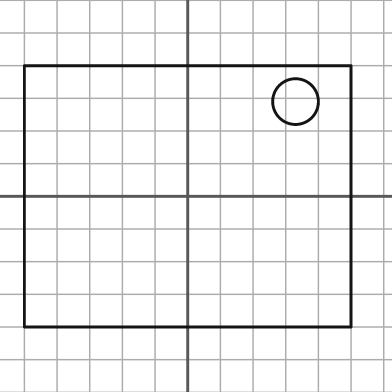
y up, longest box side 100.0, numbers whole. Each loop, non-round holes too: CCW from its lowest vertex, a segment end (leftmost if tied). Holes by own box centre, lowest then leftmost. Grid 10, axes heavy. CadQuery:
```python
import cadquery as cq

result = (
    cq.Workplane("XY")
    .moveTo(-50.0, -40.0)
    .lineTo(50.0, -40.0)
    .lineTo(50.0, 40.0)
    .lineTo(-50.0, 40.0)
    .close()
    .moveTo(33.0, 29.0)
    .circle(7.0)
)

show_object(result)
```